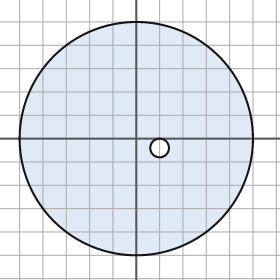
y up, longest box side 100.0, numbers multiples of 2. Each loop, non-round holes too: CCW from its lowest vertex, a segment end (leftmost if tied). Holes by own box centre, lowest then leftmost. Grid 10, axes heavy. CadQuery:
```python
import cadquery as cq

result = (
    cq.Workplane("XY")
    .moveTo(0.0, 0.0)
    .circle(50.0)
    .moveTo(10.0, -4.0)
    .circle(4.0)
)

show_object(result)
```